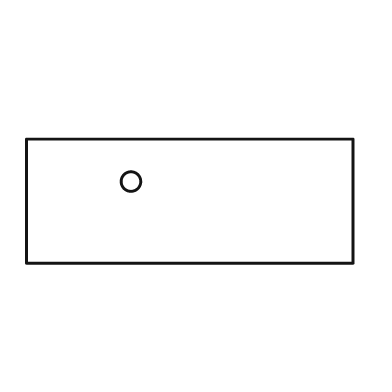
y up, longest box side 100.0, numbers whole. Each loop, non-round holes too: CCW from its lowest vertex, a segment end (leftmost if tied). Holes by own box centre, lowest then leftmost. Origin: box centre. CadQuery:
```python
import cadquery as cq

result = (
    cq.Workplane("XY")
    .moveTo(-50.0, -19.0)
    .lineTo(50.0, -19.0)
    .lineTo(50.0, 19.0)
    .lineTo(-50.0, 19.0)
    .close()
    .moveTo(-18.0, 6.0)
    .circle(3.0)
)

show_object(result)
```